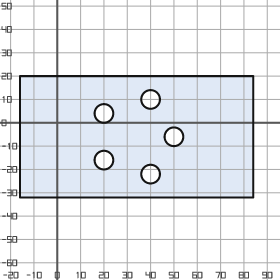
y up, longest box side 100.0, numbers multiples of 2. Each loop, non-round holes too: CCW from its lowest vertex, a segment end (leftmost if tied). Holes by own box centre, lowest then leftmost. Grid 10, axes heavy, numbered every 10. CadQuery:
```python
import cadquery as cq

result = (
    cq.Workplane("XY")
    .moveTo(-16.0, -32.0)
    .lineTo(84.0, -32.0)
    .lineTo(84.0, 20.0)
    .lineTo(-16.0, 20.0)
    .close()
    .moveTo(40.0, -22.0)
    .circle(4.0)
    .moveTo(20.0, -16.0)
    .circle(4.0)
    .moveTo(50.0, -6.0)
    .circle(4.0)
    .moveTo(20.0, 4.0)
    .circle(4.0)
    .moveTo(40.0, 10.0)
    .circle(4.0)
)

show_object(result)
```